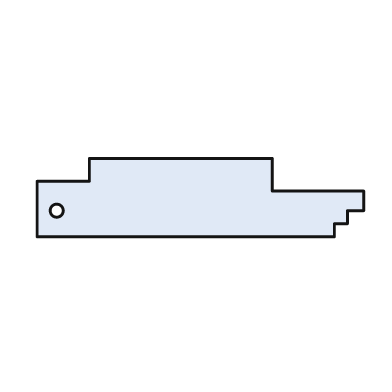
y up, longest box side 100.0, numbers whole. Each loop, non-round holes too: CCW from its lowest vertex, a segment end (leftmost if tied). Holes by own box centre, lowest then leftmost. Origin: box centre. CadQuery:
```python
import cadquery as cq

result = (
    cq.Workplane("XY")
    .moveTo(-50.0, -12.0)
    .lineTo(41.0, -12.0)
    .lineTo(41.0, -8.0)
    .lineTo(45.0, -8.0)
    .lineTo(45.0, -4.0)
    .lineTo(50.0, -4.0)
    .lineTo(50.0, 2.0)
    .lineTo(22.0, 2.0)
    .lineTo(22.0, 12.0)
    .lineTo(-34.0, 12.0)
    .lineTo(-34.0, 5.0)
    .lineTo(-50.0, 5.0)
    .close()
    .moveTo(-44.0, -4.0)
    .circle(2.0)
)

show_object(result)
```